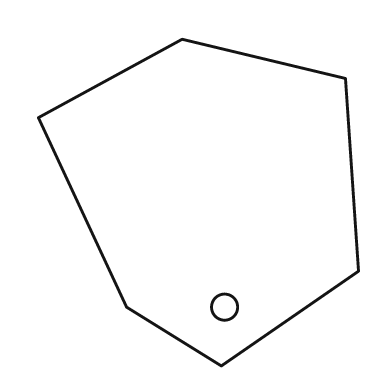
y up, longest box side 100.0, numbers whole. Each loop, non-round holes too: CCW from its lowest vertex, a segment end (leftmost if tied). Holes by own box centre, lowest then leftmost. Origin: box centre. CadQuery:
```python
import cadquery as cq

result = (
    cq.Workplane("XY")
    .moveTo(7.0, -50.0)
    .lineTo(49.0, -21.0)
    .lineTo(45.0, 38.0)
    .lineTo(-5.0, 50.0)
    .lineTo(-49.0, 26.0)
    .lineTo(-22.0, -32.0)
    .close()
    .moveTo(8.0, -32.0)
    .circle(4.0)
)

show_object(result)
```